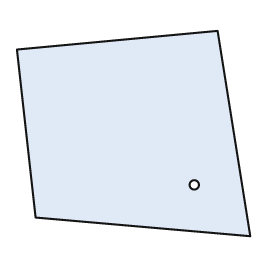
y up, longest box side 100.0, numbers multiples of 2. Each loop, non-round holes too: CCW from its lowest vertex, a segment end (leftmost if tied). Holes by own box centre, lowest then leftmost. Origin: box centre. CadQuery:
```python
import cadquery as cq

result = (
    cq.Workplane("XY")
    .moveTo(50.0, -44.0)
    .lineTo(36.0, 44.0)
    .lineTo(-50.0, 36.0)
    .lineTo(-42.0, -36.0)
    .close()
    .moveTo(26.0, -22.0)
    .circle(2.0)
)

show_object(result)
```